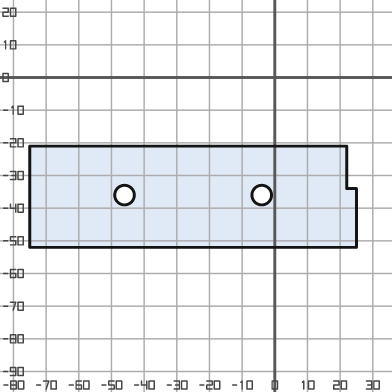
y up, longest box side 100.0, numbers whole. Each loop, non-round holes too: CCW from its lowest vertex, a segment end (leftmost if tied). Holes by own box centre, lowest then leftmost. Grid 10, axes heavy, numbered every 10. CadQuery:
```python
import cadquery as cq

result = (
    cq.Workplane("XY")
    .moveTo(-75.0, -52.0)
    .lineTo(25.0, -52.0)
    .lineTo(25.0, -34.0)
    .lineTo(22.0, -34.0)
    .lineTo(22.0, -21.0)
    .lineTo(-75.0, -21.0)
    .close()
    .moveTo(-46.0, -36.0)
    .circle(3.0)
    .moveTo(-4.0, -36.0)
    .circle(3.0)
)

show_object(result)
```